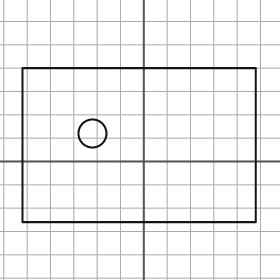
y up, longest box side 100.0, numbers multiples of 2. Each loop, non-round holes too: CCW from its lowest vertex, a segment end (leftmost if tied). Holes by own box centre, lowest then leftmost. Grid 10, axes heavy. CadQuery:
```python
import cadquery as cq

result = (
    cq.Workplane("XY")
    .moveTo(-52.0, -26.0)
    .lineTo(48.0, -26.0)
    .lineTo(48.0, 40.0)
    .lineTo(-52.0, 40.0)
    .close()
    .moveTo(-22.0, 12.0)
    .circle(6.0)
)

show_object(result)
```